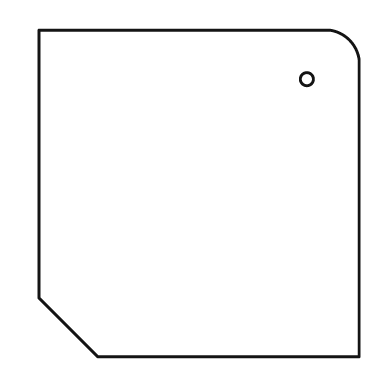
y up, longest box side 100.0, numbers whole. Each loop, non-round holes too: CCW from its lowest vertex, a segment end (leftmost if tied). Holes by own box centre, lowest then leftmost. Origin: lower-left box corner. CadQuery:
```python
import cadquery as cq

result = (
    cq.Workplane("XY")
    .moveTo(18.0, 0.0)
    .lineTo(98.0, 0.0)
    .lineTo(98.0, 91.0)
    .threePointArc((95.0, 97.0), (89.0, 100.0))
    .lineTo(0.0, 100.0)
    .lineTo(0.0, 18.0)
    .close()
    .moveTo(82.0, 85.0)
    .circle(2.0)
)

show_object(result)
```